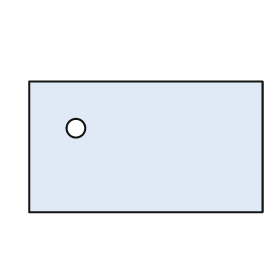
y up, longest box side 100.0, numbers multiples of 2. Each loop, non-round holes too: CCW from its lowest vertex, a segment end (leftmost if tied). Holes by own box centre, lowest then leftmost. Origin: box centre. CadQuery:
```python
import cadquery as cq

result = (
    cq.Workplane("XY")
    .moveTo(-50.0, -28.0)
    .lineTo(50.0, -28.0)
    .lineTo(50.0, 28.0)
    .lineTo(-50.0, 28.0)
    .close()
    .moveTo(-30.0, 8.0)
    .circle(4.0)
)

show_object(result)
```